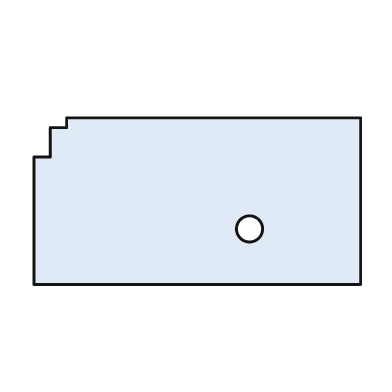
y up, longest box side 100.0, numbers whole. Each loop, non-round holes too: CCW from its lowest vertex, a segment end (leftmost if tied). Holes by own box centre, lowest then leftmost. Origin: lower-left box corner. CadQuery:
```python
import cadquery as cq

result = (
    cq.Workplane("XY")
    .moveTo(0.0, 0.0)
    .lineTo(100.0, 0.0)
    .lineTo(100.0, 51.0)
    .lineTo(10.0, 51.0)
    .lineTo(10.0, 48.0)
    .lineTo(5.0, 48.0)
    .lineTo(5.0, 39.0)
    .lineTo(0.0, 39.0)
    .close()
    .moveTo(66.0, 17.0)
    .circle(4.0)
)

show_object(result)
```